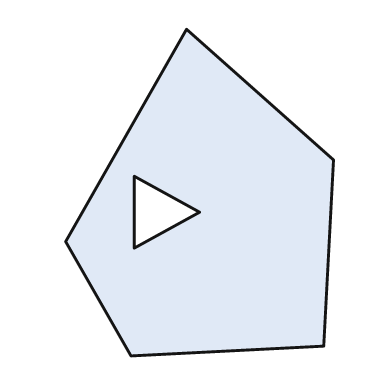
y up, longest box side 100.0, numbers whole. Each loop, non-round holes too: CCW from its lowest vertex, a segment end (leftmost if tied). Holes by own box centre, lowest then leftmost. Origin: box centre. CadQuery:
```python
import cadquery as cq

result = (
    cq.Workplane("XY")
    .moveTo(-21.0, -50.0)
    .lineTo(38.0, -47.0)
    .lineTo(41.0, 10.0)
    .lineTo(-4.0, 50.0)
    .lineTo(-41.0, -15.0)
    .close()
    .moveTo(-20.0, -17.0)
    .lineTo(0.0, -6.0)
    .lineTo(-20.0, 5.0)
    .close()
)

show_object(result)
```